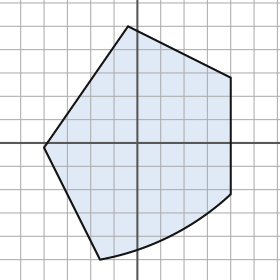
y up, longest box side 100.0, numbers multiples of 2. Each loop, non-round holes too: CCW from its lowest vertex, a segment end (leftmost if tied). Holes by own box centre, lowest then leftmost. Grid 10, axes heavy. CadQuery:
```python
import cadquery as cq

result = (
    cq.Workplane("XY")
    .moveTo(-16.0, -50.0)
    .threePointArc((14.0, -40.0), (40.0, -22.0))
    .lineTo(40.0, 28.0)
    .lineTo(-4.0, 50.0)
    .lineTo(-40.0, -2.0)
    .close()
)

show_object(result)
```